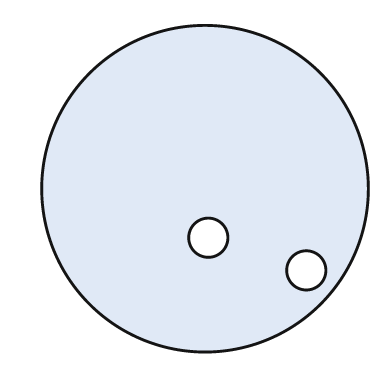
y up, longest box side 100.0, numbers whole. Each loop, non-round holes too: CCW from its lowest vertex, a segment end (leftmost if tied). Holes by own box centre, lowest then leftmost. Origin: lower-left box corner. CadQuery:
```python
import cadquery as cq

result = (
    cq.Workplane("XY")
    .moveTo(50.0, 50.0)
    .circle(50.0)
    .moveTo(81.0, 25.0)
    .circle(6.0)
    .moveTo(51.0, 35.0)
    .circle(6.0)
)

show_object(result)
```